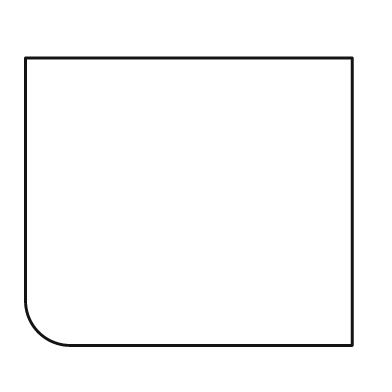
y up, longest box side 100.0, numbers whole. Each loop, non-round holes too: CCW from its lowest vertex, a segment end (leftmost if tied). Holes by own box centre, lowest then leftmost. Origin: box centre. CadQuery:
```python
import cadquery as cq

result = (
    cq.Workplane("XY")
    .moveTo(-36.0, -44.0)
    .lineTo(50.0, -44.0)
    .lineTo(50.0, 44.0)
    .lineTo(-50.0, 44.0)
    .lineTo(-50.0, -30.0)
    .threePointArc((-46.0, -40.0), (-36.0, -44.0))
    .close()
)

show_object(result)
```